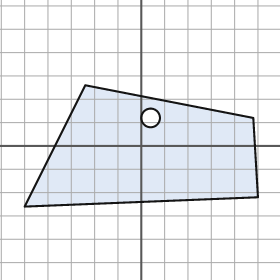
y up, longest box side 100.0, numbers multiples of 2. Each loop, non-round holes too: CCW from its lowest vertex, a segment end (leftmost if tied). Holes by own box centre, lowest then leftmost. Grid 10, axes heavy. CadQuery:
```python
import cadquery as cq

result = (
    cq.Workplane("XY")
    .moveTo(-50.0, -26.0)
    .lineTo(50.0, -22.0)
    .lineTo(48.0, 12.0)
    .lineTo(-24.0, 26.0)
    .close()
    .moveTo(4.0, 12.0)
    .circle(4.0)
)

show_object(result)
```